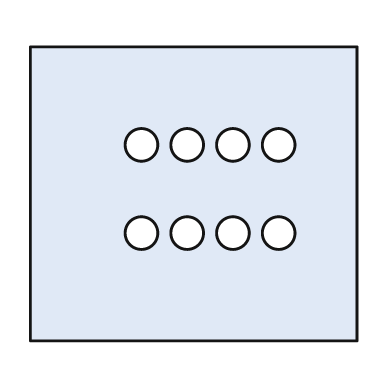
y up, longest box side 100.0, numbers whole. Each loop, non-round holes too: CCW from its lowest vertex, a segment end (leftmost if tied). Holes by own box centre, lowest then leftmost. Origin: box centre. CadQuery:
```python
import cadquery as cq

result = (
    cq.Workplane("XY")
    .moveTo(-50.0, -45.0)
    .lineTo(50.0, -45.0)
    .lineTo(50.0, 45.0)
    .lineTo(-50.0, 45.0)
    .close()
    .moveTo(-16.0, -12.0)
    .circle(5.0)
    .moveTo(-2.0, -12.0)
    .circle(5.0)
    .moveTo(12.0, -12.0)
    .circle(5.0)
    .moveTo(26.0, -12.0)
    .circle(5.0)
    .moveTo(-16.0, 15.0)
    .circle(5.0)
    .moveTo(-2.0, 15.0)
    .circle(5.0)
    .moveTo(12.0, 15.0)
    .circle(5.0)
    .moveTo(26.0, 15.0)
    .circle(5.0)
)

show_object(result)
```